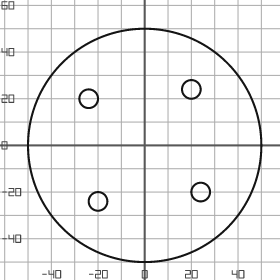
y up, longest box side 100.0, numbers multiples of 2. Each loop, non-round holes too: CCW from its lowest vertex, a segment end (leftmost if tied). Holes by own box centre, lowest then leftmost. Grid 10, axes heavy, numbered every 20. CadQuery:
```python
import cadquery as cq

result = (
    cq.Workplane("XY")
    .moveTo(0.0, 0.0)
    .circle(50.0)
    .moveTo(-20.0, -24.0)
    .circle(4.0)
    .moveTo(24.0, -20.0)
    .circle(4.0)
    .moveTo(-24.0, 20.0)
    .circle(4.0)
    .moveTo(20.0, 24.0)
    .circle(4.0)
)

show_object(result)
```